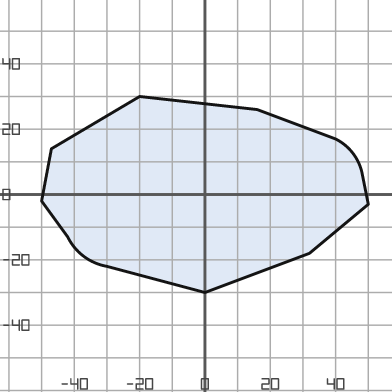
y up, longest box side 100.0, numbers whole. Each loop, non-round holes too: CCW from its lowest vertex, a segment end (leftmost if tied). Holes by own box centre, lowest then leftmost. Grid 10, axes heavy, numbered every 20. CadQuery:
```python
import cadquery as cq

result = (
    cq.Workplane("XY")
    .moveTo(0.0, -30.0)
    .lineTo(32.0, -18.0)
    .lineTo(50.0, -3.0)
    .lineTo(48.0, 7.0)
    .threePointArc((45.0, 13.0), (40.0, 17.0))
    .lineTo(16.0, 26.0)
    .lineTo(-20.0, 30.0)
    .lineTo(-47.0, 14.0)
    .lineTo(-50.0, -2.0)
    .lineTo(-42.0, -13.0)
    .threePointArc((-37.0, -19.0), (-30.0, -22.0))
    .close()
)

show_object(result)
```